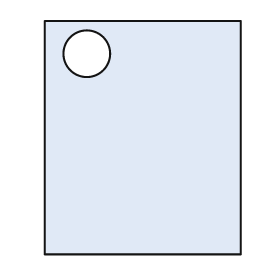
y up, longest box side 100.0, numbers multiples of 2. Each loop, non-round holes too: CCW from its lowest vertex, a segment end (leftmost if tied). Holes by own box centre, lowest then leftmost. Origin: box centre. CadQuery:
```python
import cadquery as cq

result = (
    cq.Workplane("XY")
    .moveTo(-42.0, -50.0)
    .lineTo(42.0, -50.0)
    .lineTo(42.0, 50.0)
    .lineTo(-42.0, 50.0)
    .close()
    .moveTo(-24.0, 36.0)
    .circle(10.0)
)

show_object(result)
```